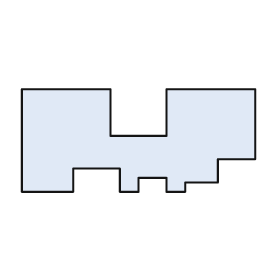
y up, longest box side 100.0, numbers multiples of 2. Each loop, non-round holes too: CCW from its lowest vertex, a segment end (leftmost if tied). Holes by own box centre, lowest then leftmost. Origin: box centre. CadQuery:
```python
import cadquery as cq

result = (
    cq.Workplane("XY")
    .moveTo(-50.0, -22.0)
    .lineTo(-28.0, -22.0)
    .lineTo(-28.0, -12.0)
    .lineTo(-8.0, -12.0)
    .lineTo(-8.0, -22.0)
    .lineTo(0.0, -22.0)
    .lineTo(0.0, -16.0)
    .lineTo(12.0, -16.0)
    .lineTo(12.0, -22.0)
    .lineTo(20.0, -22.0)
    .lineTo(20.0, -18.0)
    .lineTo(34.0, -18.0)
    .lineTo(34.0, -8.0)
    .lineTo(50.0, -8.0)
    .lineTo(50.0, 22.0)
    .lineTo(12.0, 22.0)
    .lineTo(12.0, 2.0)
    .lineTo(-12.0, 2.0)
    .lineTo(-12.0, 22.0)
    .lineTo(-50.0, 22.0)
    .close()
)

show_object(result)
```